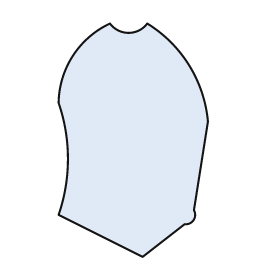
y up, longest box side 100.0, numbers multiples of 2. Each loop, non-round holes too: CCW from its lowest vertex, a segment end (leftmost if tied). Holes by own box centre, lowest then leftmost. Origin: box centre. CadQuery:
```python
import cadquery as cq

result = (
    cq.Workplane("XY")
    .moveTo(4.0, -50.0)
    .lineTo(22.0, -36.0)
    .threePointArc((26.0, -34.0), (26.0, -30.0))
    .lineTo(32.0, 8.0)
    .threePointArc((24.0, 32.0), (6.0, 50.0))
    .threePointArc((-2.0, 46.0), (-10.0, 50.0))
    .threePointArc((-26.0, 36.0), (-32.0, 16.0))
    .threePointArc((-28.0, -8.0), (-32.0, -32.0))
    .close()
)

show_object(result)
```